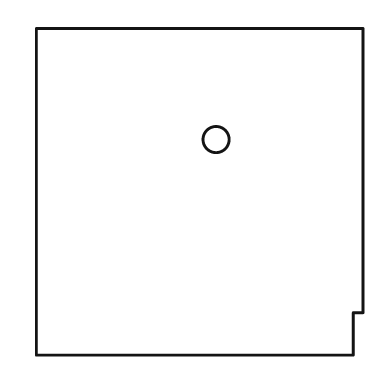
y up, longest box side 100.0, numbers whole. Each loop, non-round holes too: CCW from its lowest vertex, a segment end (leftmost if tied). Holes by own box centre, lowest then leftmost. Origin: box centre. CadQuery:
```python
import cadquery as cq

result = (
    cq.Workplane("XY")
    .moveTo(-50.0, -50.0)
    .lineTo(47.0, -50.0)
    .lineTo(47.0, -37.0)
    .lineTo(50.0, -37.0)
    .lineTo(50.0, 50.0)
    .lineTo(-50.0, 50.0)
    .close()
    .moveTo(5.0, 16.0)
    .circle(4.0)
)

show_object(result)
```